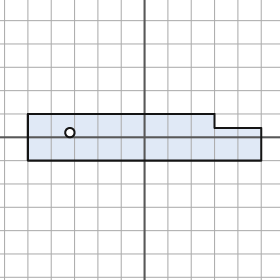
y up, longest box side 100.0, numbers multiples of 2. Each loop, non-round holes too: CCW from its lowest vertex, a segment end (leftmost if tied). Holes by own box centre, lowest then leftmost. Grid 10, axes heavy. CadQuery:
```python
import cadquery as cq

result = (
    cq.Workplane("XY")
    .moveTo(-50.0, -10.0)
    .lineTo(50.0, -10.0)
    .lineTo(50.0, 4.0)
    .lineTo(30.0, 4.0)
    .lineTo(30.0, 10.0)
    .lineTo(-50.0, 10.0)
    .close()
    .moveTo(-32.0, 2.0)
    .circle(2.0)
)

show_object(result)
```